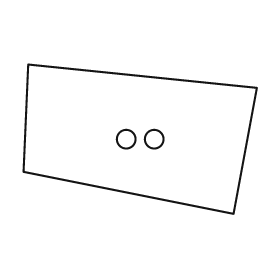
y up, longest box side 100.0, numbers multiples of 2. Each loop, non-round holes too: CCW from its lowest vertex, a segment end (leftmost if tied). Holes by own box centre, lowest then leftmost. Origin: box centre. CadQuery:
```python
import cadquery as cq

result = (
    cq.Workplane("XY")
    .moveTo(40.0, -32.0)
    .lineTo(50.0, 22.0)
    .lineTo(-48.0, 32.0)
    .lineTo(-50.0, -14.0)
    .close()
    .moveTo(-6.0, 0.0)
    .circle(4.0)
    .moveTo(6.0, 0.0)
    .circle(4.0)
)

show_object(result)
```